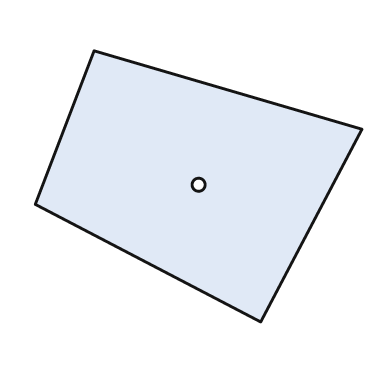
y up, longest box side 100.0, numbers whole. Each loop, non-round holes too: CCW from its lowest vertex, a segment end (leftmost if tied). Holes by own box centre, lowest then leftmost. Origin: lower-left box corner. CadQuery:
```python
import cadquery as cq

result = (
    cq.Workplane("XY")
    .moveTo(69.0, 0.0)
    .lineTo(100.0, 59.0)
    .lineTo(18.0, 83.0)
    .lineTo(0.0, 36.0)
    .close()
    .moveTo(50.0, 42.0)
    .circle(2.0)
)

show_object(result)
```